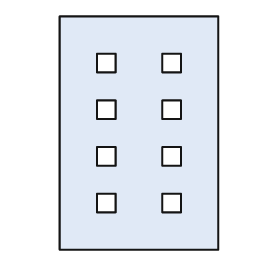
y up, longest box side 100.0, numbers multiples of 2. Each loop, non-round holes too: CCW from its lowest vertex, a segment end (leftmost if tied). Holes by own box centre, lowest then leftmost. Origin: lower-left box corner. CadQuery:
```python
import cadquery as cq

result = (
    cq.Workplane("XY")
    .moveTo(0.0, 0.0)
    .lineTo(68.0, 0.0)
    .lineTo(68.0, 100.0)
    .lineTo(0.0, 100.0)
    .close()
    .moveTo(16.0, 16.0)
    .lineTo(24.0, 16.0)
    .lineTo(24.0, 24.0)
    .lineTo(16.0, 24.0)
    .close()
    .moveTo(44.0, 16.0)
    .lineTo(52.0, 16.0)
    .lineTo(52.0, 24.0)
    .lineTo(44.0, 24.0)
    .close()
    .moveTo(16.0, 36.0)
    .lineTo(24.0, 36.0)
    .lineTo(24.0, 44.0)
    .lineTo(16.0, 44.0)
    .close()
    .moveTo(44.0, 36.0)
    .lineTo(52.0, 36.0)
    .lineTo(52.0, 44.0)
    .lineTo(44.0, 44.0)
    .close()
    .moveTo(16.0, 56.0)
    .lineTo(24.0, 56.0)
    .lineTo(24.0, 64.0)
    .lineTo(16.0, 64.0)
    .close()
    .moveTo(44.0, 56.0)
    .lineTo(52.0, 56.0)
    .lineTo(52.0, 64.0)
    .lineTo(44.0, 64.0)
    .close()
    .moveTo(16.0, 76.0)
    .lineTo(24.0, 76.0)
    .lineTo(24.0, 84.0)
    .lineTo(16.0, 84.0)
    .close()
    .moveTo(44.0, 76.0)
    .lineTo(52.0, 76.0)
    .lineTo(52.0, 84.0)
    .lineTo(44.0, 84.0)
    .close()
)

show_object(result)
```